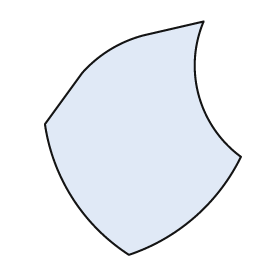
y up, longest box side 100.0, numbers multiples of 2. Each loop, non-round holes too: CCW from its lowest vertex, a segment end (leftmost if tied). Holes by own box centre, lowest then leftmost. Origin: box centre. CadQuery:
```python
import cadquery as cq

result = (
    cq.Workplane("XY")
    .moveTo(-6.0, -50.0)
    .threePointArc((22.0, -34.0), (42.0, -8.0))
    .threePointArc((24.0, 18.0), (26.0, 50.0))
    .lineTo(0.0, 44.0)
    .threePointArc((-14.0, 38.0), (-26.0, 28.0))
    .lineTo(-42.0, 6.0)
    .threePointArc((-30.0, -26.0), (-6.0, -50.0))
    .close()
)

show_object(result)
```